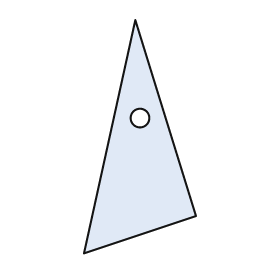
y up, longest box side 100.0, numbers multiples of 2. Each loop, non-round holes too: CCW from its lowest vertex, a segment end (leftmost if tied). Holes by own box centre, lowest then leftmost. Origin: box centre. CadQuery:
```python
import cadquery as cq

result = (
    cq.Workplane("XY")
    .moveTo(-24.0, -50.0)
    .lineTo(24.0, -34.0)
    .lineTo(-2.0, 50.0)
    .close()
    .moveTo(0.0, 8.0)
    .circle(4.0)
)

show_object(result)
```